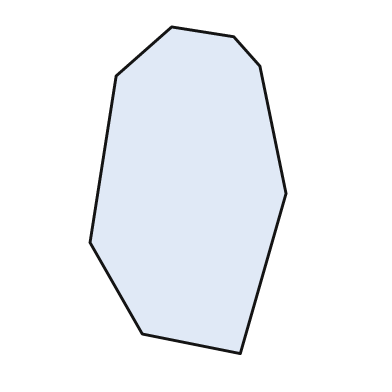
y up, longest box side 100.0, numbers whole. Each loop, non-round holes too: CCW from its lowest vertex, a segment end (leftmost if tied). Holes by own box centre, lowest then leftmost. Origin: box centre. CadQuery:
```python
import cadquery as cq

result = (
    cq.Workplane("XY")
    .moveTo(16.0, -50.0)
    .lineTo(30.0, -1.0)
    .lineTo(22.0, 38.0)
    .lineTo(14.0, 47.0)
    .lineTo(-5.0, 50.0)
    .lineTo(-22.0, 35.0)
    .lineTo(-30.0, -16.0)
    .lineTo(-14.0, -44.0)
    .close()
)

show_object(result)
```